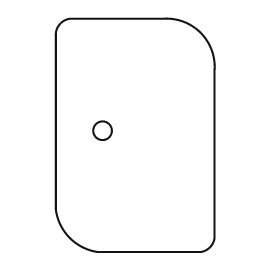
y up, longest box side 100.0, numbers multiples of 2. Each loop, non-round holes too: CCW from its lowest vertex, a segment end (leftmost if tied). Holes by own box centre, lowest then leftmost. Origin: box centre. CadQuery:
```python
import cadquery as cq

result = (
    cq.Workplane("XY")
    .moveTo(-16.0, -50.0)
    .lineTo(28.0, -50.0)
    .threePointArc((32.0, -48.0), (34.0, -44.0))
    .lineTo(34.0, 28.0)
    .threePointArc((28.0, 44.0), (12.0, 50.0))
    .lineTo(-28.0, 50.0)
    .threePointArc((-32.0, 48.0), (-34.0, 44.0))
    .lineTo(-34.0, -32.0)
    .threePointArc((-28.0, -44.0), (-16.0, -50.0))
    .close()
    .moveTo(-14.0, 2.0)
    .circle(4.0)
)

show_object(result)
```